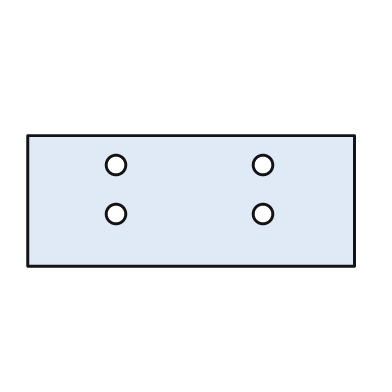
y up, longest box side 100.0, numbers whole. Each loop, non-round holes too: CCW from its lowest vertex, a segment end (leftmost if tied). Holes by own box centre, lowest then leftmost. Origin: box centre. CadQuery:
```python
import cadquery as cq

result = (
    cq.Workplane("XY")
    .moveTo(-50.0, -20.0)
    .lineTo(50.0, -20.0)
    .lineTo(50.0, 20.0)
    .lineTo(-50.0, 20.0)
    .close()
    .moveTo(-23.0, -4.0)
    .circle(3.0)
    .moveTo(22.0, -4.0)
    .circle(3.0)
    .moveTo(-23.0, 11.0)
    .circle(3.0)
    .moveTo(22.0, 11.0)
    .circle(3.0)
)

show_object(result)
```